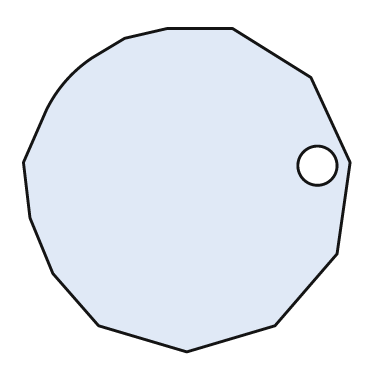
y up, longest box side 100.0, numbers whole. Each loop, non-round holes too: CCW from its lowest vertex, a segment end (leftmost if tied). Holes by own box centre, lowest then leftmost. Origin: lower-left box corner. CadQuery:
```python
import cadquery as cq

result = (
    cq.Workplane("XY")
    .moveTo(50.0, 0.0)
    .lineTo(77.0, 8.0)
    .lineTo(96.0, 30.0)
    .lineTo(100.0, 58.0)
    .lineTo(88.0, 84.0)
    .lineTo(64.0, 99.0)
    .lineTo(44.0, 99.0)
    .lineTo(31.0, 96.0)
    .lineTo(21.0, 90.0)
    .threePointArc((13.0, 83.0), (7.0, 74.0))
    .lineTo(0.0, 58.0)
    .lineTo(2.0, 41.0)
    .lineTo(9.0, 24.0)
    .lineTo(23.0, 8.0)
    .close()
    .moveTo(90.0, 57.0)
    .circle(6.0)
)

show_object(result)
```